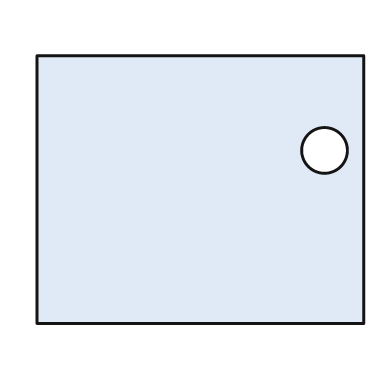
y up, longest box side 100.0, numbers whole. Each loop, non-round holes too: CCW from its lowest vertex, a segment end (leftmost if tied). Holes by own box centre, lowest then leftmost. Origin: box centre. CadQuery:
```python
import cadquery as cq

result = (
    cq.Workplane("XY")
    .moveTo(-50.0, -41.0)
    .lineTo(50.0, -41.0)
    .lineTo(50.0, 41.0)
    .lineTo(-50.0, 41.0)
    .close()
    .moveTo(38.0, 12.0)
    .circle(7.0)
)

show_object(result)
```